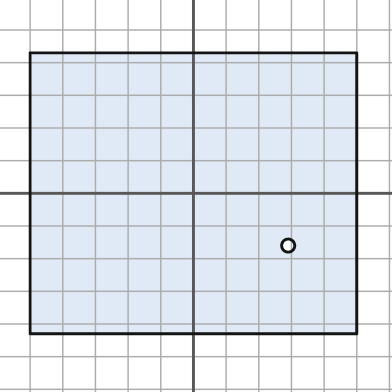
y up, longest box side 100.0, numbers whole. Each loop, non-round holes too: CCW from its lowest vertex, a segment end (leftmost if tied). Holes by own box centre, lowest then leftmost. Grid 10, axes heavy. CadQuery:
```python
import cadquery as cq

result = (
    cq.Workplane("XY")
    .moveTo(-50.0, -43.0)
    .lineTo(50.0, -43.0)
    .lineTo(50.0, 43.0)
    .lineTo(-50.0, 43.0)
    .close()
    .moveTo(29.0, -16.0)
    .circle(2.0)
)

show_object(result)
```